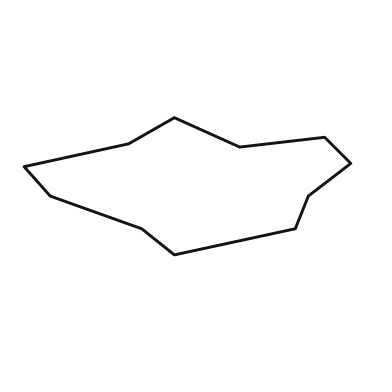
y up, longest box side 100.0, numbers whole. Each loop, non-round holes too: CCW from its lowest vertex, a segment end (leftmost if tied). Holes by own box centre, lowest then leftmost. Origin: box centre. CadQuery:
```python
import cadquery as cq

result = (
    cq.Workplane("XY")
    .moveTo(-4.0, -21.0)
    .lineTo(33.0, -13.0)
    .lineTo(37.0, -3.0)
    .lineTo(50.0, 7.0)
    .lineTo(42.0, 15.0)
    .lineTo(16.0, 12.0)
    .lineTo(-4.0, 21.0)
    .lineTo(-18.0, 13.0)
    .lineTo(-50.0, 6.0)
    .lineTo(-42.0, -3.0)
    .lineTo(-14.0, -13.0)
    .close()
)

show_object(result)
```